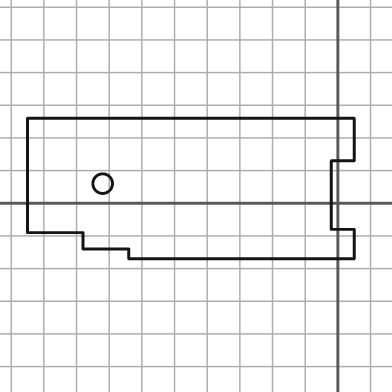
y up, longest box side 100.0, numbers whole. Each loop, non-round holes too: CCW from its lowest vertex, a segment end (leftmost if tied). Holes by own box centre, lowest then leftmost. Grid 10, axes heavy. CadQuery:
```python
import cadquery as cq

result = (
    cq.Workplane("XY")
    .moveTo(-64.0, -17.0)
    .lineTo(5.0, -17.0)
    .lineTo(5.0, -8.0)
    .lineTo(-2.0, -8.0)
    .lineTo(-2.0, 13.0)
    .lineTo(5.0, 13.0)
    .lineTo(5.0, 26.0)
    .lineTo(-95.0, 26.0)
    .lineTo(-95.0, -9.0)
    .lineTo(-78.0, -9.0)
    .lineTo(-78.0, -14.0)
    .lineTo(-64.0, -14.0)
    .close()
    .moveTo(-72.0, 6.0)
    .circle(3.0)
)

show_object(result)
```